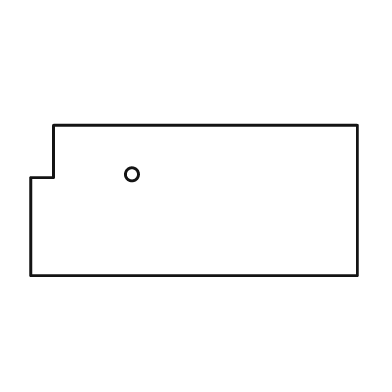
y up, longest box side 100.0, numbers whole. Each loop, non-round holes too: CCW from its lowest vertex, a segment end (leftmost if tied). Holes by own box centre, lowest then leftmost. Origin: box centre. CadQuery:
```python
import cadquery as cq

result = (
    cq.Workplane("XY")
    .moveTo(-50.0, -23.0)
    .lineTo(50.0, -23.0)
    .lineTo(50.0, 23.0)
    .lineTo(-43.0, 23.0)
    .lineTo(-43.0, 7.0)
    .lineTo(-50.0, 7.0)
    .close()
    .moveTo(-19.0, 8.0)
    .circle(2.0)
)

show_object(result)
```